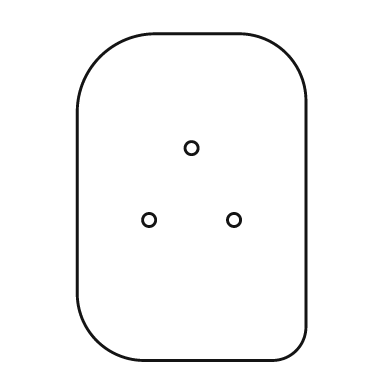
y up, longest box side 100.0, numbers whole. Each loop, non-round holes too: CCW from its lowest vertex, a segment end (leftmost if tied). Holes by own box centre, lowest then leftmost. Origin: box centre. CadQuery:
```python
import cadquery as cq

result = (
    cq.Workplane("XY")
    .moveTo(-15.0, -50.0)
    .lineTo(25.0, -50.0)
    .threePointArc((32.0, -47.0), (35.0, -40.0))
    .lineTo(35.0, 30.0)
    .threePointArc((29.0, 44.0), (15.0, 50.0))
    .lineTo(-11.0, 50.0)
    .threePointArc((-28.0, 43.0), (-35.0, 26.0))
    .lineTo(-35.0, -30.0)
    .threePointArc((-29.0, -44.0), (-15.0, -50.0))
    .close()
    .moveTo(-13.0, -7.0)
    .circle(2.0)
    .moveTo(13.0, -7.0)
    .circle(2.0)
    .moveTo(0.0, 15.0)
    .circle(2.0)
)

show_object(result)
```